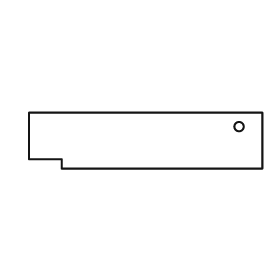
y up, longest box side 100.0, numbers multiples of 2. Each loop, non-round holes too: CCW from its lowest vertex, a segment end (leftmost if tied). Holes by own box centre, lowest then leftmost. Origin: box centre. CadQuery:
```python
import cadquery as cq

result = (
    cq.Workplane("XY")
    .moveTo(-36.0, -12.0)
    .lineTo(50.0, -12.0)
    .lineTo(50.0, 12.0)
    .lineTo(-50.0, 12.0)
    .lineTo(-50.0, -8.0)
    .lineTo(-36.0, -8.0)
    .close()
    .moveTo(40.0, 6.0)
    .circle(2.0)
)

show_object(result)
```